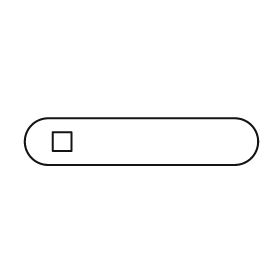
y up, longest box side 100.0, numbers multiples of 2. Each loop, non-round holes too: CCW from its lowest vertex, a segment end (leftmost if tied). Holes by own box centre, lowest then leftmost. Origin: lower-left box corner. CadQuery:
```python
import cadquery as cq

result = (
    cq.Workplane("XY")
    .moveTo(10.0, 0.0)
    .lineTo(90.0, 0.0)
    .threePointArc((100.0, 10.0), (90.0, 20.0))
    .lineTo(10.0, 20.0)
    .threePointArc((0.0, 10.0), (10.0, 0.0))
    .close()
    .moveTo(12.0, 6.0)
    .lineTo(20.0, 6.0)
    .lineTo(20.0, 14.0)
    .lineTo(12.0, 14.0)
    .close()
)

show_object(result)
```